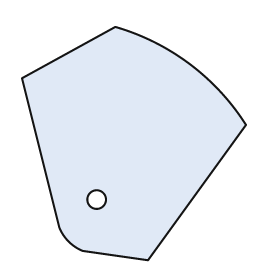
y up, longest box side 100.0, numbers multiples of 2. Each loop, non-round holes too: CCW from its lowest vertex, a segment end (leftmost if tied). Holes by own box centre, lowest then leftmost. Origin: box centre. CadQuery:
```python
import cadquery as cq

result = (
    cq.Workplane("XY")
    .moveTo(6.0, -50.0)
    .lineTo(48.0, 8.0)
    .threePointArc((24.0, 34.0), (-8.0, 50.0))
    .lineTo(-48.0, 28.0)
    .lineTo(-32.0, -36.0)
    .threePointArc((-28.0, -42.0), (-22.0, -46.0))
    .close()
    .moveTo(-16.0, -24.0)
    .circle(4.0)
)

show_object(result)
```